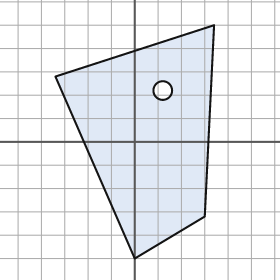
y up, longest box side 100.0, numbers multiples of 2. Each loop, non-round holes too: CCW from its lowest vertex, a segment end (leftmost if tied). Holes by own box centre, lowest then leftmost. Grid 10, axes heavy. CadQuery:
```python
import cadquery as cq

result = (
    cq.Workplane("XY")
    .moveTo(0.0, -50.0)
    .lineTo(30.0, -32.0)
    .lineTo(34.0, 50.0)
    .lineTo(-34.0, 28.0)
    .close()
    .moveTo(12.0, 22.0)
    .circle(4.0)
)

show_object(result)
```